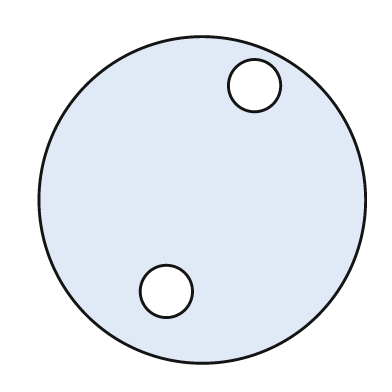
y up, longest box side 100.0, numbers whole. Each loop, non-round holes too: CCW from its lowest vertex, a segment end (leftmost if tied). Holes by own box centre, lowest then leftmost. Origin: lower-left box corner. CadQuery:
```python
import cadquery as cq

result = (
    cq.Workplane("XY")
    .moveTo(50.0, 50.0)
    .circle(50.0)
    .moveTo(39.0, 22.0)
    .circle(8.0)
    .moveTo(66.0, 85.0)
    .circle(8.0)
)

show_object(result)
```